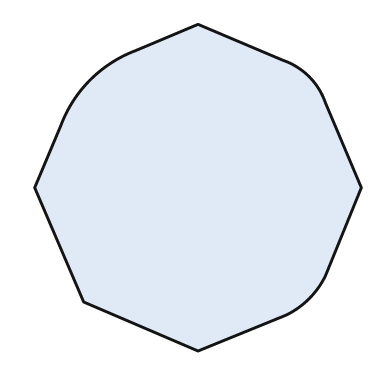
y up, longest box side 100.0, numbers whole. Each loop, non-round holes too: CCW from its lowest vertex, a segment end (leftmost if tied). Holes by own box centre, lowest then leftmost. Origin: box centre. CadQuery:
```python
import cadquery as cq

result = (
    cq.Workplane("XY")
    .moveTo(0.0, -50.0)
    .lineTo(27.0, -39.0)
    .threePointArc((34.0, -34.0), (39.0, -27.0))
    .lineTo(50.0, 0.0)
    .lineTo(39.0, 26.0)
    .threePointArc((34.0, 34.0), (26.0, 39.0))
    .lineTo(0.0, 50.0)
    .lineTo(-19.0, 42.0)
    .threePointArc((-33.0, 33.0), (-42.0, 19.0))
    .lineTo(-50.0, 0.0)
    .lineTo(-35.0, -35.0)
    .close()
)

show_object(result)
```